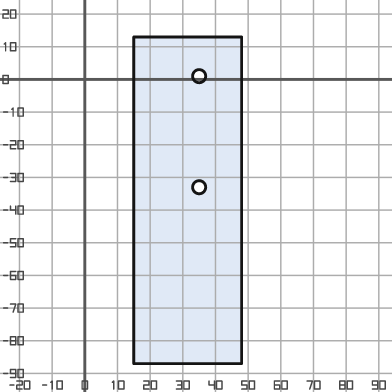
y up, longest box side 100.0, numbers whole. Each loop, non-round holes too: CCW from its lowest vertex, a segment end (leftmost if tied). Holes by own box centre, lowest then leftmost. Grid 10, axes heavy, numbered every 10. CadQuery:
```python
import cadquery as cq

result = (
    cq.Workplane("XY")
    .moveTo(15.0, -87.0)
    .lineTo(48.0, -87.0)
    .lineTo(48.0, 13.0)
    .lineTo(15.0, 13.0)
    .close()
    .moveTo(35.0, -33.0)
    .circle(2.0)
    .moveTo(35.0, 1.0)
    .circle(2.0)
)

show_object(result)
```